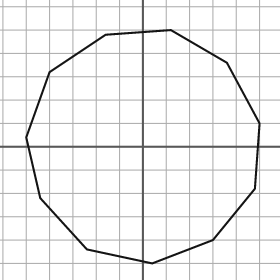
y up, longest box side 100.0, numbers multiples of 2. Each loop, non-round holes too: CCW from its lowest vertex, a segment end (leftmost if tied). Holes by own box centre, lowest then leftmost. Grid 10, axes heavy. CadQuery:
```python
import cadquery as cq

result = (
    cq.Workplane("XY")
    .moveTo(4.0, -50.0)
    .lineTo(30.0, -40.0)
    .lineTo(48.0, -18.0)
    .lineTo(50.0, 10.0)
    .lineTo(36.0, 36.0)
    .lineTo(12.0, 50.0)
    .lineTo(-16.0, 48.0)
    .lineTo(-40.0, 32.0)
    .lineTo(-50.0, 4.0)
    .lineTo(-44.0, -22.0)
    .lineTo(-24.0, -44.0)
    .close()
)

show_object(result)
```